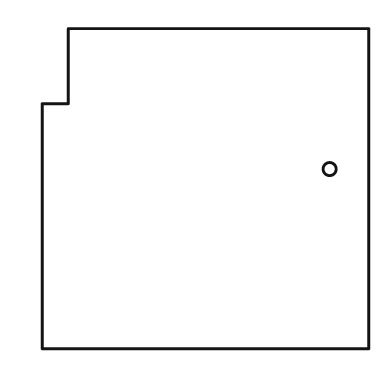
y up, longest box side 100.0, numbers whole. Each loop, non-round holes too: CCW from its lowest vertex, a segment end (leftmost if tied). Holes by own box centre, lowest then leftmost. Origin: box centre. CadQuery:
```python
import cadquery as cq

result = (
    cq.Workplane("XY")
    .moveTo(-50.0, -49.0)
    .lineTo(50.0, -49.0)
    .lineTo(50.0, 49.0)
    .lineTo(-42.0, 49.0)
    .lineTo(-42.0, 26.0)
    .lineTo(-50.0, 26.0)
    .close()
    .moveTo(38.0, 6.0)
    .circle(2.0)
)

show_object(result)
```